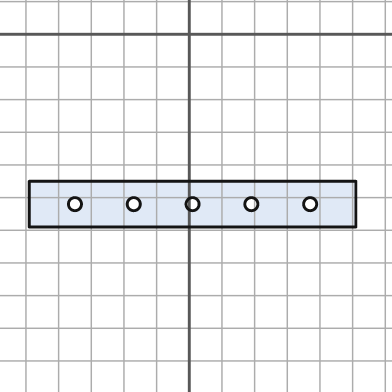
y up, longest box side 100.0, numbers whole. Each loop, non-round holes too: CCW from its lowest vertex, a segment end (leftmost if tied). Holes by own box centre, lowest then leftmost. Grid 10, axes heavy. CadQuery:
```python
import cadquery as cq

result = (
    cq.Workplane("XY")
    .moveTo(-49.0, -59.0)
    .lineTo(51.0, -59.0)
    .lineTo(51.0, -45.0)
    .lineTo(-49.0, -45.0)
    .close()
    .moveTo(-35.0, -52.0)
    .circle(2.0)
    .moveTo(-17.0, -52.0)
    .circle(2.0)
    .moveTo(1.0, -52.0)
    .circle(2.0)
    .moveTo(19.0, -52.0)
    .circle(2.0)
    .moveTo(37.0, -52.0)
    .circle(2.0)
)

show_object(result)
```